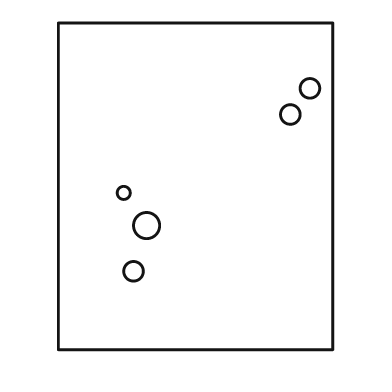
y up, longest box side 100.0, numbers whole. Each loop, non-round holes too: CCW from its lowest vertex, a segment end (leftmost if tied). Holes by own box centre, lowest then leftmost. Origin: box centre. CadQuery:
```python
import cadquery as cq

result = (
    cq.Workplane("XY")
    .moveTo(-42.0, -50.0)
    .lineTo(42.0, -50.0)
    .lineTo(42.0, 50.0)
    .lineTo(-42.0, 50.0)
    .close()
    .moveTo(-19.0, -26.0)
    .circle(3.0)
    .moveTo(-15.0, -12.0)
    .circle(4.0)
    .moveTo(-22.0, -2.0)
    .circle(2.0)
    .moveTo(29.0, 22.0)
    .circle(3.0)
    .moveTo(35.0, 30.0)
    .circle(3.0)
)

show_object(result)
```